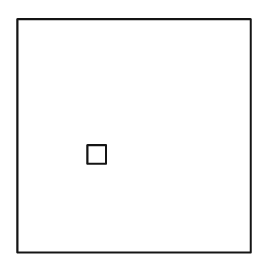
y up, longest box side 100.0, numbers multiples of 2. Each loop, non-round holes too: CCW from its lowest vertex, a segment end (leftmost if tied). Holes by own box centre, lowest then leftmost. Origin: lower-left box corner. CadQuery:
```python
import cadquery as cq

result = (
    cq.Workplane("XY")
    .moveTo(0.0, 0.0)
    .lineTo(100.0, 0.0)
    .lineTo(100.0, 100.0)
    .lineTo(0.0, 100.0)
    .close()
    .moveTo(30.0, 38.0)
    .lineTo(38.0, 38.0)
    .lineTo(38.0, 46.0)
    .lineTo(30.0, 46.0)
    .close()
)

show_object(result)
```